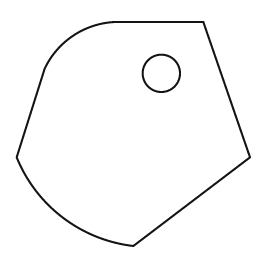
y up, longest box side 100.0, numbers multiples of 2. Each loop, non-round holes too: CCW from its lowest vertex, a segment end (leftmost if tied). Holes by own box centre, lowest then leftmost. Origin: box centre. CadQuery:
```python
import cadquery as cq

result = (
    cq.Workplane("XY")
    .moveTo(0.0, -48.0)
    .lineTo(50.0, -10.0)
    .lineTo(30.0, 48.0)
    .lineTo(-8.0, 48.0)
    .threePointArc((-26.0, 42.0), (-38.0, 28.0))
    .lineTo(-50.0, -10.0)
    .threePointArc((-30.0, -36.0), (0.0, -48.0))
    .close()
    .moveTo(12.0, 26.0)
    .circle(8.0)
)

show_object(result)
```